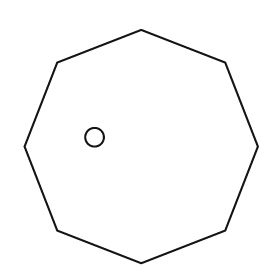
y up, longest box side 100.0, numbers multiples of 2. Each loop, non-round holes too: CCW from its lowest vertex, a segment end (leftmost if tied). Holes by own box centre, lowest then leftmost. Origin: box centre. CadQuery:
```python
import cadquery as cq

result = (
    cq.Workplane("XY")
    .moveTo(0.0, -50.0)
    .lineTo(36.0, -36.0)
    .lineTo(50.0, 0.0)
    .lineTo(36.0, 36.0)
    .lineTo(0.0, 50.0)
    .lineTo(-36.0, 36.0)
    .lineTo(-50.0, 0.0)
    .lineTo(-36.0, -36.0)
    .close()
    .moveTo(-20.0, 4.0)
    .circle(4.0)
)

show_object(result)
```